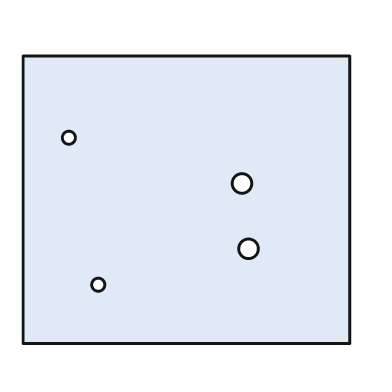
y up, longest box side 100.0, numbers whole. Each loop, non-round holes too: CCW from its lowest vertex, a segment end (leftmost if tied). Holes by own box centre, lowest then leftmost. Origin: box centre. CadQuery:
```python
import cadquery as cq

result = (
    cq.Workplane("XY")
    .moveTo(-50.0, -44.0)
    .lineTo(50.0, -44.0)
    .lineTo(50.0, 44.0)
    .lineTo(-50.0, 44.0)
    .close()
    .moveTo(-27.0, -26.0)
    .circle(2.0)
    .moveTo(19.0, -15.0)
    .circle(3.0)
    .moveTo(17.0, 5.0)
    .circle(3.0)
    .moveTo(-36.0, 19.0)
    .circle(2.0)
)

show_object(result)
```